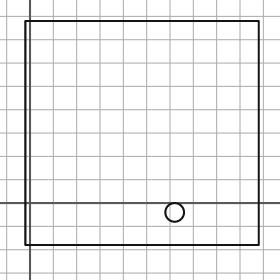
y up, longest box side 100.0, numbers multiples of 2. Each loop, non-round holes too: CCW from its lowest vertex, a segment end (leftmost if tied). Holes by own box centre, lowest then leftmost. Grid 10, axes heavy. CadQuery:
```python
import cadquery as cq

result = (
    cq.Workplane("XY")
    .moveTo(-2.0, -18.0)
    .lineTo(98.0, -18.0)
    .lineTo(98.0, 78.0)
    .lineTo(-2.0, 78.0)
    .close()
    .moveTo(62.0, -4.0)
    .circle(4.0)
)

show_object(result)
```